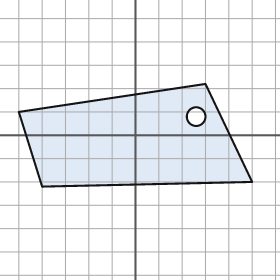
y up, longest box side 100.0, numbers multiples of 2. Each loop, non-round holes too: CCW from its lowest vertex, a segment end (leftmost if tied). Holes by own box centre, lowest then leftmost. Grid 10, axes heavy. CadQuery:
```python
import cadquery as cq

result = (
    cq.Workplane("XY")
    .moveTo(-40.0, -22.0)
    .lineTo(50.0, -20.0)
    .lineTo(30.0, 22.0)
    .lineTo(-50.0, 10.0)
    .close()
    .moveTo(26.0, 8.0)
    .circle(4.0)
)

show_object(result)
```